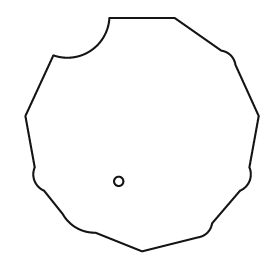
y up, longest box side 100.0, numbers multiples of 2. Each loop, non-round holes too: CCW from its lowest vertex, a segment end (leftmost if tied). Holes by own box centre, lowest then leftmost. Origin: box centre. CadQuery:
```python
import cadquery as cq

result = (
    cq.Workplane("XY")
    .moveTo(0.0, -50.0)
    .lineTo(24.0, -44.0)
    .threePointArc((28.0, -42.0), (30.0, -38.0))
    .lineTo(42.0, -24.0)
    .threePointArc((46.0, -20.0), (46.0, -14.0))
    .lineTo(50.0, 8.0)
    .lineTo(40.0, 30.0)
    .threePointArc((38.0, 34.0), (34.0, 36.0))
    .lineTo(14.0, 50.0)
    .lineTo(-14.0, 50.0)
    .threePointArc((-22.0, 36.0), (-38.0, 34.0))
    .lineTo(-50.0, 8.0)
    .lineTo(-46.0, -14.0)
    .threePointArc((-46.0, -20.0), (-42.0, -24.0))
    .lineTo(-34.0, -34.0)
    .threePointArc((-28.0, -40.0), (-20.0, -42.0))
    .close()
    .moveTo(-10.0, -20.0)
    .circle(2.0)
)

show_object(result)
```